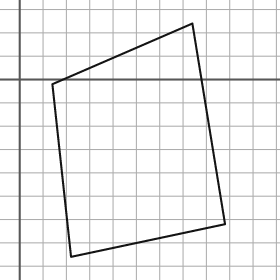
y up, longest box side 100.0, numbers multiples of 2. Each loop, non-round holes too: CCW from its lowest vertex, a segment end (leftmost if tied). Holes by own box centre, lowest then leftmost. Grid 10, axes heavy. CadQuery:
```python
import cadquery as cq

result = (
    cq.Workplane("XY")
    .moveTo(22.0, -76.0)
    .lineTo(88.0, -62.0)
    .lineTo(74.0, 24.0)
    .lineTo(14.0, -2.0)
    .close()
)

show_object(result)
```